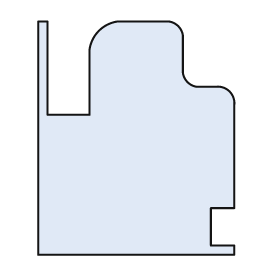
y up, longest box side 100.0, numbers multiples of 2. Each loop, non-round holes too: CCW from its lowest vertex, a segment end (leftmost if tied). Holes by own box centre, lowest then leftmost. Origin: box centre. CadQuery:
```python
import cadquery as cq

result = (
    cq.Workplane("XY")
    .moveTo(-42.0, -50.0)
    .lineTo(42.0, -50.0)
    .lineTo(42.0, -46.0)
    .lineTo(32.0, -46.0)
    .lineTo(32.0, -30.0)
    .lineTo(42.0, -30.0)
    .lineTo(42.0, 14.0)
    .threePointArc((40.0, 20.0), (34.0, 22.0))
    .lineTo(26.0, 22.0)
    .threePointArc((22.0, 24.0), (20.0, 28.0))
    .lineTo(20.0, 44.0)
    .threePointArc((18.0, 48.0), (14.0, 50.0))
    .lineTo(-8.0, 50.0)
    .threePointArc((-16.0, 46.0), (-20.0, 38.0))
    .lineTo(-20.0, 10.0)
    .lineTo(-38.0, 10.0)
    .lineTo(-38.0, 50.0)
    .lineTo(-42.0, 50.0)
    .close()
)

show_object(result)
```